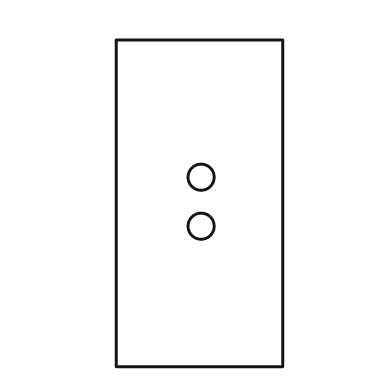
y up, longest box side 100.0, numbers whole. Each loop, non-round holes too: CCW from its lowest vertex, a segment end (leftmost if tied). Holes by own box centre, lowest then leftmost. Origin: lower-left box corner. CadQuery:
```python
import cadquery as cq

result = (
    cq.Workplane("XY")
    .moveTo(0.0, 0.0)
    .lineTo(51.0, 0.0)
    .lineTo(51.0, 100.0)
    .lineTo(0.0, 100.0)
    .close()
    .moveTo(26.0, 43.0)
    .circle(4.0)
    .moveTo(26.0, 58.0)
    .circle(4.0)
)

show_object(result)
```